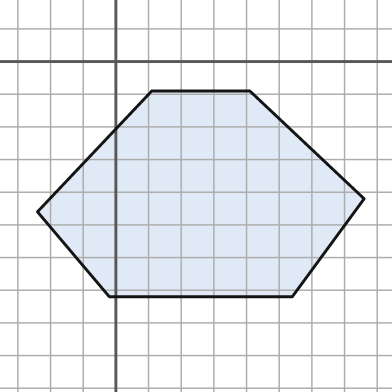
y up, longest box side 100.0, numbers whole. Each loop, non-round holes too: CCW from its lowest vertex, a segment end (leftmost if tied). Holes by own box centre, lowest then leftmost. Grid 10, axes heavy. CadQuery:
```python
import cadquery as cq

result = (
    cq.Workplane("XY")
    .moveTo(-2.0, -72.0)
    .lineTo(54.0, -72.0)
    .lineTo(76.0, -42.0)
    .lineTo(41.0, -9.0)
    .lineTo(11.0, -9.0)
    .lineTo(-24.0, -46.0)
    .close()
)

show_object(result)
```